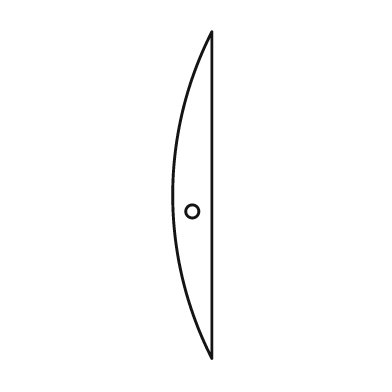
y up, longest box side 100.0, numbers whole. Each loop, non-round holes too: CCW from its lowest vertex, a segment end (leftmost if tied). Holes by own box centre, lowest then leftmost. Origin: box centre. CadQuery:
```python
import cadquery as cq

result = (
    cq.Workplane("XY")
    .moveTo(6.0, -50.0)
    .lineTo(6.0, 50.0)
    .threePointArc((-6.0, 0.0), (6.0, -50.0))
    .close()
    .moveTo(0.0, -5.0)
    .circle(2.0)
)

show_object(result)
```